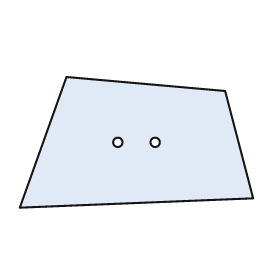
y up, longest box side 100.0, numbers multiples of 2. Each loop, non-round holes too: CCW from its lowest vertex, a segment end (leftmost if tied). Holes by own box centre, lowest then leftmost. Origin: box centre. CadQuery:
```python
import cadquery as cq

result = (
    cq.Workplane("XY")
    .moveTo(-50.0, -28.0)
    .lineTo(50.0, -24.0)
    .lineTo(38.0, 22.0)
    .lineTo(-30.0, 28.0)
    .close()
    .moveTo(-8.0, 0.0)
    .circle(2.0)
    .moveTo(8.0, 0.0)
    .circle(2.0)
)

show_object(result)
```